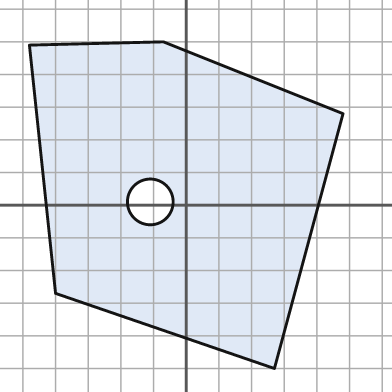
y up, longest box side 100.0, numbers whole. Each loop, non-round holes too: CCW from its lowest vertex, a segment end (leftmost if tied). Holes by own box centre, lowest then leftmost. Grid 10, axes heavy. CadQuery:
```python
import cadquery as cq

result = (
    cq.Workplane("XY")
    .moveTo(27.0, -50.0)
    .lineTo(48.0, 28.0)
    .lineTo(-7.0, 50.0)
    .lineTo(-48.0, 49.0)
    .lineTo(-40.0, -27.0)
    .close()
    .moveTo(-11.0, 1.0)
    .circle(7.0)
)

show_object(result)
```